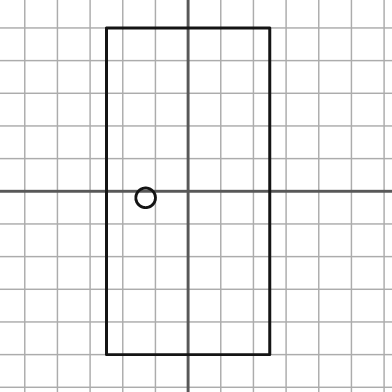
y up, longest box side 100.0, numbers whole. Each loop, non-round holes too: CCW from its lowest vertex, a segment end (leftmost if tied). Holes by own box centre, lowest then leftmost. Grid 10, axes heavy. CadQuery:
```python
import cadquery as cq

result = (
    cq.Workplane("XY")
    .moveTo(-25.0, -50.0)
    .lineTo(25.0, -50.0)
    .lineTo(25.0, 50.0)
    .lineTo(-25.0, 50.0)
    .close()
    .moveTo(-13.0, -2.0)
    .circle(3.0)
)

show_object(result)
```